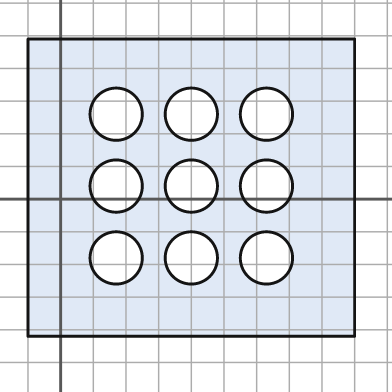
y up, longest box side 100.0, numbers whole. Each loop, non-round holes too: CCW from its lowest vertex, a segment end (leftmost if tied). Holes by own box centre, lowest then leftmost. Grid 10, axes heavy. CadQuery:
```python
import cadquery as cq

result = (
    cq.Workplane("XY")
    .moveTo(-10.0, -42.0)
    .lineTo(90.0, -42.0)
    .lineTo(90.0, 49.0)
    .lineTo(-10.0, 49.0)
    .close()
    .moveTo(17.0, -18.0)
    .circle(8.0)
    .moveTo(40.0, -18.0)
    .circle(8.0)
    .moveTo(63.0, -18.0)
    .circle(8.0)
    .moveTo(17.0, 4.0)
    .circle(8.0)
    .moveTo(40.0, 4.0)
    .circle(8.0)
    .moveTo(63.0, 4.0)
    .circle(8.0)
    .moveTo(17.0, 26.0)
    .circle(8.0)
    .moveTo(40.0, 26.0)
    .circle(8.0)
    .moveTo(63.0, 26.0)
    .circle(8.0)
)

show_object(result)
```